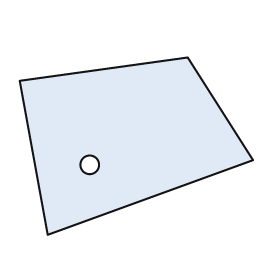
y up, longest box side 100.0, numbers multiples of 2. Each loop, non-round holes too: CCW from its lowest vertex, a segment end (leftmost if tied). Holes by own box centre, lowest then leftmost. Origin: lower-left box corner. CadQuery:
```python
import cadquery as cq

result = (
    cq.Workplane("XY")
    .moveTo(12.0, 0.0)
    .lineTo(100.0, 32.0)
    .lineTo(72.0, 76.0)
    .lineTo(0.0, 66.0)
    .close()
    .moveTo(30.0, 30.0)
    .circle(4.0)
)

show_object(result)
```